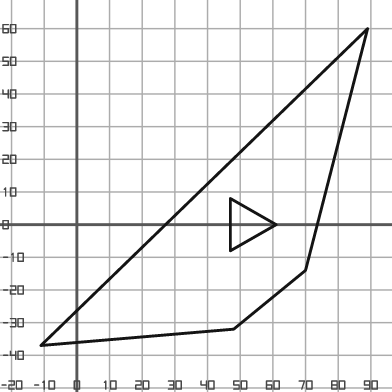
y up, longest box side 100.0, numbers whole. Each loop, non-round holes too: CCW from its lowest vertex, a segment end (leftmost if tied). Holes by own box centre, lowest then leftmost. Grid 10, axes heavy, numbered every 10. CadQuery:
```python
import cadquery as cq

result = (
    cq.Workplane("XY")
    .moveTo(-11.0, -37.0)
    .lineTo(48.0, -32.0)
    .lineTo(70.0, -14.0)
    .lineTo(89.0, 60.0)
    .close()
    .moveTo(47.0, -8.0)
    .lineTo(61.0, 0.0)
    .lineTo(47.0, 8.0)
    .close()
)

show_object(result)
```